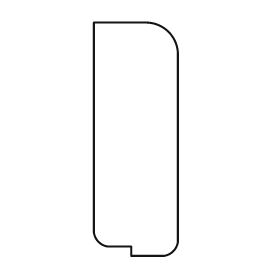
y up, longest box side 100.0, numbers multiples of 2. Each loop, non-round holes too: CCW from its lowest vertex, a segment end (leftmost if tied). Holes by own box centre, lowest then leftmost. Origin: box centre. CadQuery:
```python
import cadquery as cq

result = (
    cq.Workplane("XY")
    .moveTo(-2.0, -50.0)
    .lineTo(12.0, -50.0)
    .threePointArc((16.0, -48.0), (18.0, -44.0))
    .lineTo(18.0, 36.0)
    .threePointArc((14.0, 46.0), (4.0, 50.0))
    .lineTo(-18.0, 50.0)
    .lineTo(-18.0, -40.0)
    .threePointArc((-16.0, -44.0), (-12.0, -46.0))
    .lineTo(-2.0, -46.0)
    .close()
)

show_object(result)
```